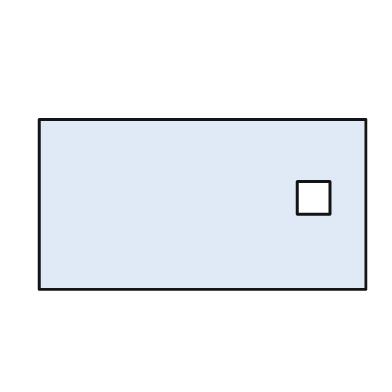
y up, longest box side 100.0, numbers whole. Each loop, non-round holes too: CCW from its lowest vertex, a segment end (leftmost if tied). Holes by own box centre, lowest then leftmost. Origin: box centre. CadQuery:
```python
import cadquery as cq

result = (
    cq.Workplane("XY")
    .moveTo(-50.0, -26.0)
    .lineTo(50.0, -26.0)
    .lineTo(50.0, 26.0)
    .lineTo(-50.0, 26.0)
    .close()
    .moveTo(29.0, -3.0)
    .lineTo(39.0, -3.0)
    .lineTo(39.0, 7.0)
    .lineTo(29.0, 7.0)
    .close()
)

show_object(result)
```